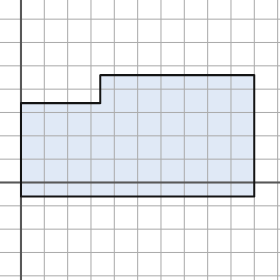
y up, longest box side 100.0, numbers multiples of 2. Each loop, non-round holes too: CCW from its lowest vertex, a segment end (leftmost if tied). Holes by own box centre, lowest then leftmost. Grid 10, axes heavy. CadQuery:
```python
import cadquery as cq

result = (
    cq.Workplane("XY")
    .moveTo(0.0, -6.0)
    .lineTo(100.0, -6.0)
    .lineTo(100.0, 46.0)
    .lineTo(34.0, 46.0)
    .lineTo(34.0, 34.0)
    .lineTo(0.0, 34.0)
    .close()
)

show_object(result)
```